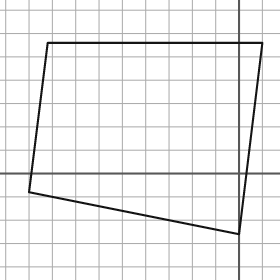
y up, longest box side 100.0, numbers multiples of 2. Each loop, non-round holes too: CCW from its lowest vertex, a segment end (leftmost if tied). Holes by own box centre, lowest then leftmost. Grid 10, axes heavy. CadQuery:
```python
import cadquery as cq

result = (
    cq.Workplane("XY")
    .moveTo(0.0, -26.0)
    .lineTo(10.0, 56.0)
    .lineTo(-82.0, 56.0)
    .lineTo(-90.0, -8.0)
    .close()
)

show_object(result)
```